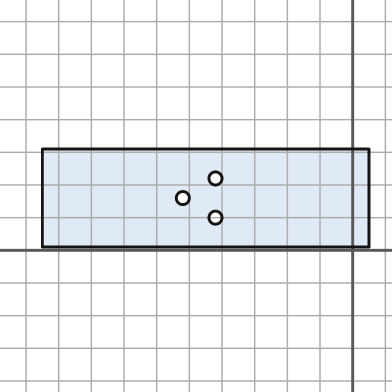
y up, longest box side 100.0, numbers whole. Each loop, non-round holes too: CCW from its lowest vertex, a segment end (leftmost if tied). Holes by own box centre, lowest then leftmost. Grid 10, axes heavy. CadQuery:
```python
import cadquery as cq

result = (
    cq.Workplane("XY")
    .moveTo(-95.0, 1.0)
    .lineTo(5.0, 1.0)
    .lineTo(5.0, 31.0)
    .lineTo(-95.0, 31.0)
    .close()
    .moveTo(-42.0, 10.0)
    .circle(2.0)
    .moveTo(-52.0, 16.0)
    .circle(2.0)
    .moveTo(-42.0, 22.0)
    .circle(2.0)
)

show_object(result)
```